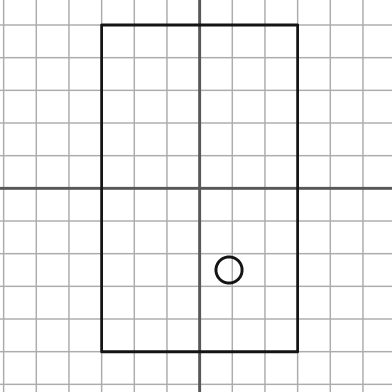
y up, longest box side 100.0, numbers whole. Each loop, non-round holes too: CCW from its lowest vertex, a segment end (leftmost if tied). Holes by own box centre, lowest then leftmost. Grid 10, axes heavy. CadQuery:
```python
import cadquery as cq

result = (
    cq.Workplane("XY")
    .moveTo(-30.0, -50.0)
    .lineTo(30.0, -50.0)
    .lineTo(30.0, 50.0)
    .lineTo(-30.0, 50.0)
    .close()
    .moveTo(9.0, -25.0)
    .circle(4.0)
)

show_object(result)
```